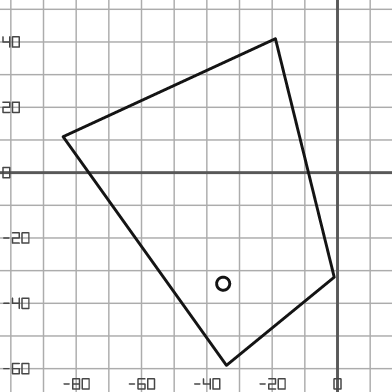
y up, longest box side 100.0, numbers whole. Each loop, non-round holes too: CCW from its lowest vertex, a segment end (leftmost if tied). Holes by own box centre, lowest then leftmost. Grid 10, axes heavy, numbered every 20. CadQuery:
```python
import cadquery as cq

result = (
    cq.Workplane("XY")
    .moveTo(-34.0, -59.0)
    .lineTo(-1.0, -32.0)
    .lineTo(-19.0, 41.0)
    .lineTo(-84.0, 11.0)
    .close()
    .moveTo(-35.0, -34.0)
    .circle(2.0)
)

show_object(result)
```